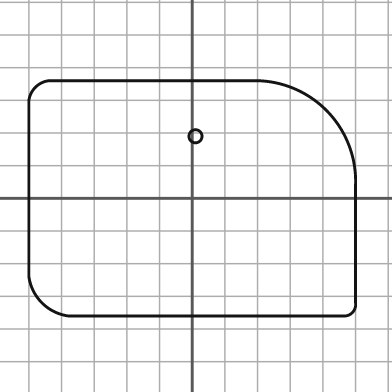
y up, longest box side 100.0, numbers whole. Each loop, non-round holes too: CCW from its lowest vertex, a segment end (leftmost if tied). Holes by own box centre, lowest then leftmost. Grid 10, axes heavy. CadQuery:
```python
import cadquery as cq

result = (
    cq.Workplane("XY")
    .moveTo(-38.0, -36.0)
    .lineTo(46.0, -36.0)
    .threePointArc((49.0, -35.0), (50.0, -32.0))
    .lineTo(50.0, 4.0)
    .threePointArc((41.0, 27.0), (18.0, 36.0))
    .lineTo(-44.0, 36.0)
    .threePointArc((-48.0, 34.0), (-50.0, 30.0))
    .lineTo(-50.0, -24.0)
    .threePointArc((-46.0, -32.0), (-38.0, -36.0))
    .close()
    .moveTo(1.0, 19.0)
    .circle(2.0)
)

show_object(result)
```